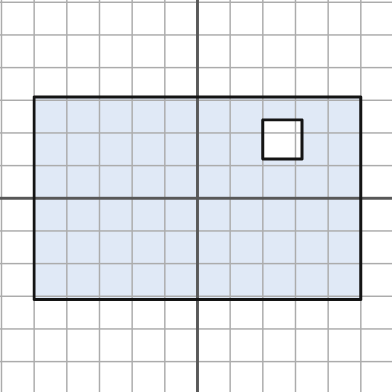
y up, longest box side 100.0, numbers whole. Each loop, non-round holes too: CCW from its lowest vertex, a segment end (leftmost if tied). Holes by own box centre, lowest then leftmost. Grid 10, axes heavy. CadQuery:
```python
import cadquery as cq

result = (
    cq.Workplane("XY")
    .moveTo(-50.0, -31.0)
    .lineTo(50.0, -31.0)
    .lineTo(50.0, 31.0)
    .lineTo(-50.0, 31.0)
    .close()
    .moveTo(20.0, 12.0)
    .lineTo(32.0, 12.0)
    .lineTo(32.0, 24.0)
    .lineTo(20.0, 24.0)
    .close()
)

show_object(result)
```